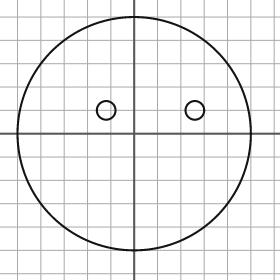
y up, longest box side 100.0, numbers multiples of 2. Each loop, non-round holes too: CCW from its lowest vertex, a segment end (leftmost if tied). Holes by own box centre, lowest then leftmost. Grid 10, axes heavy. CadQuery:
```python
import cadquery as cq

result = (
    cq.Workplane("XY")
    .moveTo(0.0, 0.0)
    .circle(50.0)
    .moveTo(-12.0, 10.0)
    .circle(4.0)
    .moveTo(26.0, 10.0)
    .circle(4.0)
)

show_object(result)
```